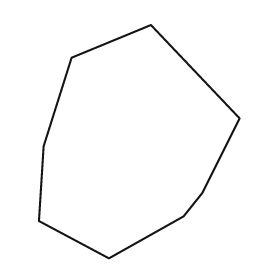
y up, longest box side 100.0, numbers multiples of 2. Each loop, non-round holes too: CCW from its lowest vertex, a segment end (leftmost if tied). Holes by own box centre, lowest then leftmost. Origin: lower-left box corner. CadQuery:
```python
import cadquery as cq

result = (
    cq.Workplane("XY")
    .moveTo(30.0, 0.0)
    .lineTo(62.0, 18.0)
    .lineTo(70.0, 28.0)
    .lineTo(86.0, 60.0)
    .lineTo(48.0, 100.0)
    .lineTo(14.0, 86.0)
    .lineTo(2.0, 48.0)
    .lineTo(0.0, 16.0)
    .close()
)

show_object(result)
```